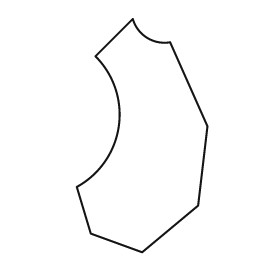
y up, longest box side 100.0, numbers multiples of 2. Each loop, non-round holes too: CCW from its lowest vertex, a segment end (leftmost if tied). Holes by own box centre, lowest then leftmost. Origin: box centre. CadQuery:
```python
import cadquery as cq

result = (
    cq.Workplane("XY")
    .moveTo(0.0, -50.0)
    .lineTo(24.0, -30.0)
    .lineTo(28.0, 4.0)
    .lineTo(12.0, 40.0)
    .threePointArc((2.0, 42.0), (-4.0, 50.0))
    .lineTo(-20.0, 34.0)
    .threePointArc((-10.0, 4.0), (-28.0, -22.0))
    .lineTo(-22.0, -42.0)
    .close()
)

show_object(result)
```